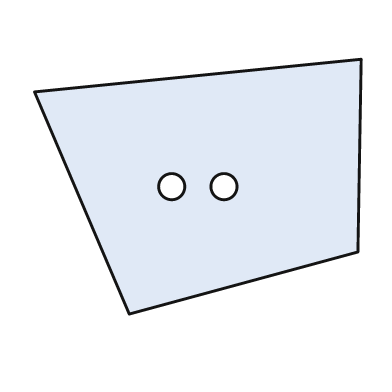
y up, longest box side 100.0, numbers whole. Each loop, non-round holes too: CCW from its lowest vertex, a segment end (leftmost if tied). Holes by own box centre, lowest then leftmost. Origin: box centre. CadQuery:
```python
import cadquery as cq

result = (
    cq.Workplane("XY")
    .moveTo(-21.0, -39.0)
    .lineTo(49.0, -20.0)
    .lineTo(50.0, 39.0)
    .lineTo(-50.0, 29.0)
    .close()
    .moveTo(-8.0, 0.0)
    .circle(4.0)
    .moveTo(8.0, 0.0)
    .circle(4.0)
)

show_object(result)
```